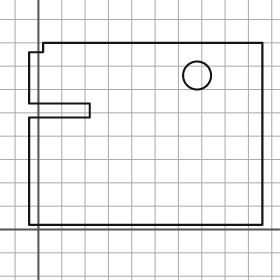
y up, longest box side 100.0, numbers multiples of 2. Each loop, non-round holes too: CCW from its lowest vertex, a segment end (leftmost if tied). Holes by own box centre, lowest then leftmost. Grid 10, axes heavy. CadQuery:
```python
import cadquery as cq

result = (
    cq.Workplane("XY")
    .moveTo(-4.0, 2.0)
    .lineTo(96.0, 2.0)
    .lineTo(96.0, 80.0)
    .lineTo(2.0, 80.0)
    .lineTo(2.0, 76.0)
    .lineTo(-4.0, 76.0)
    .lineTo(-4.0, 54.0)
    .lineTo(22.0, 54.0)
    .lineTo(22.0, 48.0)
    .lineTo(-4.0, 48.0)
    .close()
    .moveTo(68.0, 66.0)
    .circle(6.0)
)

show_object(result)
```